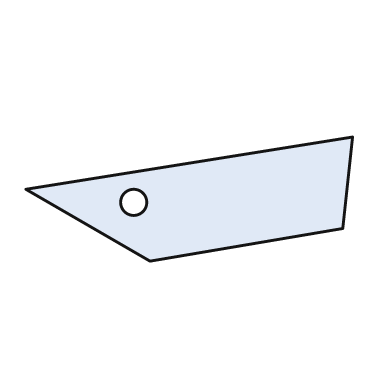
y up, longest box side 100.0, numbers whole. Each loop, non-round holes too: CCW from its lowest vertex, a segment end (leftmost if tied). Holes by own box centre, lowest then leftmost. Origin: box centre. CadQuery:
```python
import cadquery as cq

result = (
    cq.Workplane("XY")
    .moveTo(-12.0, -19.0)
    .lineTo(47.0, -9.0)
    .lineTo(50.0, 19.0)
    .lineTo(-50.0, 3.0)
    .close()
    .moveTo(-17.0, -1.0)
    .circle(4.0)
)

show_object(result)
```